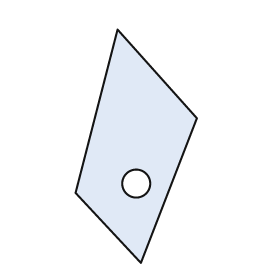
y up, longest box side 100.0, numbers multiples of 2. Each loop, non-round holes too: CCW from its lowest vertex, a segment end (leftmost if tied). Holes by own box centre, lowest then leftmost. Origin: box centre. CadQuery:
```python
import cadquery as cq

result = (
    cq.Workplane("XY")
    .moveTo(2.0, -50.0)
    .lineTo(26.0, 12.0)
    .lineTo(-8.0, 50.0)
    .lineTo(-26.0, -20.0)
    .close()
    .moveTo(0.0, -16.0)
    .circle(6.0)
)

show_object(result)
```